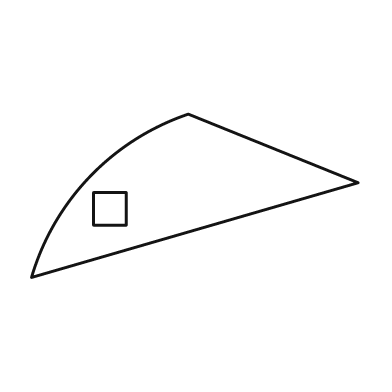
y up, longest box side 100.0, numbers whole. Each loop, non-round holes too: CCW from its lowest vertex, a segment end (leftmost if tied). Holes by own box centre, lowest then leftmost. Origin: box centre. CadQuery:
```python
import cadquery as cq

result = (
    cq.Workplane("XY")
    .moveTo(-50.0, -25.0)
    .lineTo(50.0, 4.0)
    .lineTo(-2.0, 25.0)
    .threePointArc((-32.0, 6.0), (-50.0, -25.0))
    .close()
    .moveTo(-31.0, -9.0)
    .lineTo(-21.0, -9.0)
    .lineTo(-21.0, 1.0)
    .lineTo(-31.0, 1.0)
    .close()
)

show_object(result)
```